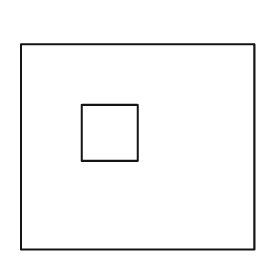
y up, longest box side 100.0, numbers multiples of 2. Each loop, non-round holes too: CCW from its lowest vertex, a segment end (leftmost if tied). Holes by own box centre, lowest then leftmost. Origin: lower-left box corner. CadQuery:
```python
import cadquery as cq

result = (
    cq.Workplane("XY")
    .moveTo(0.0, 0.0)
    .lineTo(100.0, 0.0)
    .lineTo(100.0, 88.0)
    .lineTo(0.0, 88.0)
    .close()
    .moveTo(26.0, 38.0)
    .lineTo(50.0, 38.0)
    .lineTo(50.0, 62.0)
    .lineTo(26.0, 62.0)
    .close()
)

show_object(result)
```